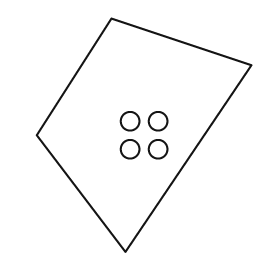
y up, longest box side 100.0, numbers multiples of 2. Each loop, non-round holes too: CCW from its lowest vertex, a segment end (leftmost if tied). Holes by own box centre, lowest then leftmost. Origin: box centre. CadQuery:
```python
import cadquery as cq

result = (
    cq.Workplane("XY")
    .moveTo(-8.0, -50.0)
    .lineTo(46.0, 30.0)
    .lineTo(-14.0, 50.0)
    .lineTo(-46.0, 0.0)
    .close()
    .moveTo(-6.0, -6.0)
    .circle(4.0)
    .moveTo(6.0, -6.0)
    .circle(4.0)
    .moveTo(-6.0, 6.0)
    .circle(4.0)
    .moveTo(6.0, 6.0)
    .circle(4.0)
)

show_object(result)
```